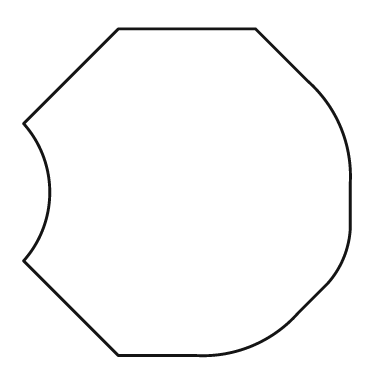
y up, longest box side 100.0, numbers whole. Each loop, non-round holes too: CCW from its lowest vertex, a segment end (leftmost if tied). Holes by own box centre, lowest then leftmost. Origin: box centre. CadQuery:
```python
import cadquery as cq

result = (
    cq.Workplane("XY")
    .moveTo(-21.0, -50.0)
    .lineTo(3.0, -50.0)
    .threePointArc((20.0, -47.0), (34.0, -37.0))
    .lineTo(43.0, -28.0)
    .threePointArc((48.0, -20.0), (50.0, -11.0))
    .lineTo(50.0, 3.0)
    .threePointArc((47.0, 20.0), (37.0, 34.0))
    .lineTo(21.0, 50.0)
    .lineTo(-21.0, 50.0)
    .lineTo(-50.0, 21.0)
    .threePointArc((-42.0, 0.0), (-50.0, -21.0))
    .close()
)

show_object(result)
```